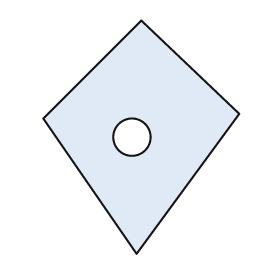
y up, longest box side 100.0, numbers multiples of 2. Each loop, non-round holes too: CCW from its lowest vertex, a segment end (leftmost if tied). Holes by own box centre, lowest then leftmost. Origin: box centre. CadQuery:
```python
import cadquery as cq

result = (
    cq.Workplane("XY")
    .moveTo(-2.0, -50.0)
    .lineTo(42.0, 10.0)
    .lineTo(0.0, 50.0)
    .lineTo(-42.0, 8.0)
    .close()
    .moveTo(-4.0, 0.0)
    .circle(8.0)
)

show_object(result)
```